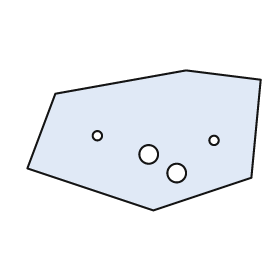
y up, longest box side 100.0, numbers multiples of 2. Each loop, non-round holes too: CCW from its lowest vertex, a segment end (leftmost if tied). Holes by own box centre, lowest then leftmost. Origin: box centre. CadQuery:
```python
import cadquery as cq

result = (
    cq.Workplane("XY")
    .moveTo(4.0, -30.0)
    .lineTo(46.0, -16.0)
    .lineTo(50.0, 26.0)
    .lineTo(18.0, 30.0)
    .lineTo(-38.0, 20.0)
    .lineTo(-50.0, -12.0)
    .close()
    .moveTo(14.0, -14.0)
    .circle(4.0)
    .moveTo(2.0, -6.0)
    .circle(4.0)
    .moveTo(30.0, 0.0)
    .circle(2.0)
    .moveTo(-20.0, 2.0)
    .circle(2.0)
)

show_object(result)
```